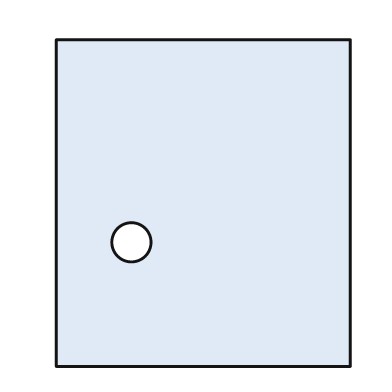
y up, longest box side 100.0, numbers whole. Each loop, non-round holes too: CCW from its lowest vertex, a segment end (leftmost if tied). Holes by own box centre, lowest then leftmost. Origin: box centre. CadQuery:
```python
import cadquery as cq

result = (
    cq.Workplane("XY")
    .moveTo(-45.0, -50.0)
    .lineTo(45.0, -50.0)
    .lineTo(45.0, 50.0)
    .lineTo(-45.0, 50.0)
    .close()
    .moveTo(-22.0, -12.0)
    .circle(6.0)
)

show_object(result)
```